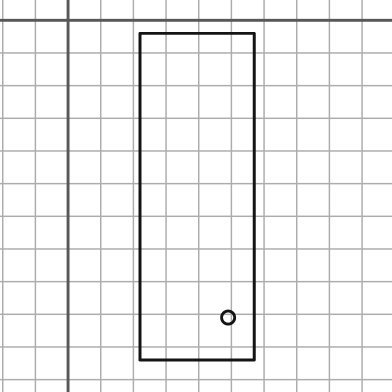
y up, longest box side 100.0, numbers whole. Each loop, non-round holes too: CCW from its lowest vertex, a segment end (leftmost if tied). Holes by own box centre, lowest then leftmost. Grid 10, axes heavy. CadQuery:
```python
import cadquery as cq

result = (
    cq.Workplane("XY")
    .moveTo(22.0, -104.0)
    .lineTo(57.0, -104.0)
    .lineTo(57.0, -4.0)
    .lineTo(22.0, -4.0)
    .close()
    .moveTo(49.0, -91.0)
    .circle(2.0)
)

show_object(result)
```